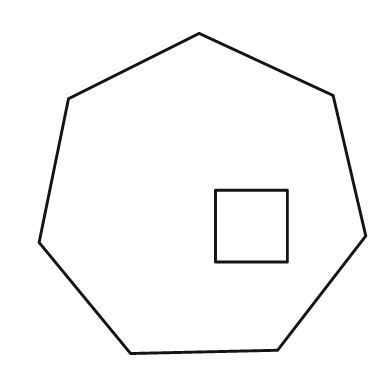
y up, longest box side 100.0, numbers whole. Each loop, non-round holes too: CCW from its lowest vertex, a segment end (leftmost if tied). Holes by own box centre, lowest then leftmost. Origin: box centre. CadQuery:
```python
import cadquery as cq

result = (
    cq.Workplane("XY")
    .moveTo(-22.0, -49.0)
    .lineTo(23.0, -48.0)
    .lineTo(50.0, -13.0)
    .lineTo(40.0, 30.0)
    .lineTo(-1.0, 49.0)
    .lineTo(-41.0, 29.0)
    .lineTo(-50.0, -15.0)
    .close()
    .moveTo(4.0, -21.0)
    .lineTo(26.0, -21.0)
    .lineTo(26.0, 1.0)
    .lineTo(4.0, 1.0)
    .close()
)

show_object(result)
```